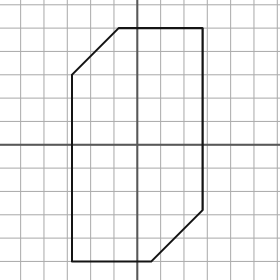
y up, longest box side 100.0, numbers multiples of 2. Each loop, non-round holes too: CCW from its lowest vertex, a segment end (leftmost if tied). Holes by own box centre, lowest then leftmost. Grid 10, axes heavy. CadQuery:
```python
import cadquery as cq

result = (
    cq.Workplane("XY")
    .moveTo(-28.0, -50.0)
    .lineTo(6.0, -50.0)
    .lineTo(28.0, -28.0)
    .lineTo(28.0, 50.0)
    .lineTo(-8.0, 50.0)
    .lineTo(-28.0, 30.0)
    .close()
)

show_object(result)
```